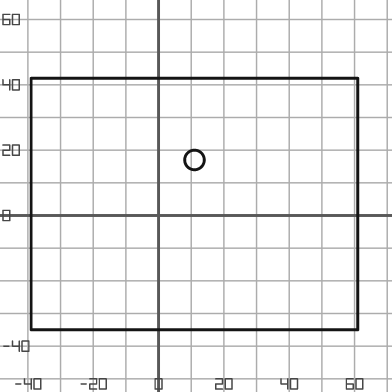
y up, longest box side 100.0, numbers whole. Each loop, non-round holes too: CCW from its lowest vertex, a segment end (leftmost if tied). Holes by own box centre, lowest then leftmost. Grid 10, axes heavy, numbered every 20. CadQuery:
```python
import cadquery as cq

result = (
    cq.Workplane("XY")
    .moveTo(-39.0, -35.0)
    .lineTo(61.0, -35.0)
    .lineTo(61.0, 42.0)
    .lineTo(-39.0, 42.0)
    .close()
    .moveTo(11.0, 17.0)
    .circle(3.0)
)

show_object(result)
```